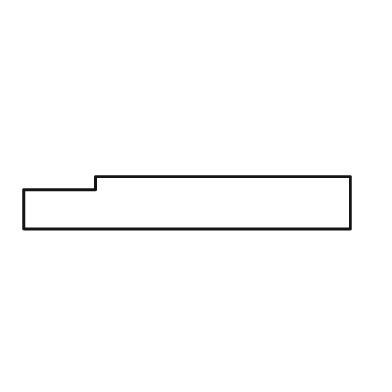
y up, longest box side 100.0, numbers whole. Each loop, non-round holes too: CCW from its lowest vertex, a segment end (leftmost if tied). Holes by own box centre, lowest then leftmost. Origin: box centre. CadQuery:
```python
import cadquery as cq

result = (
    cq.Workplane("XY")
    .moveTo(-50.0, -8.0)
    .lineTo(50.0, -8.0)
    .lineTo(50.0, 8.0)
    .lineTo(-28.0, 8.0)
    .lineTo(-28.0, 4.0)
    .lineTo(-50.0, 4.0)
    .close()
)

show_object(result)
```